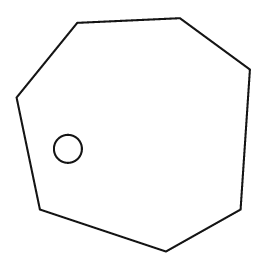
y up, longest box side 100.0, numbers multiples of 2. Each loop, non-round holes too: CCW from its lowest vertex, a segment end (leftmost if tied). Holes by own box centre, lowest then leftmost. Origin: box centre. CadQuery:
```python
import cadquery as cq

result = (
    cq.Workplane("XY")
    .moveTo(14.0, -50.0)
    .lineTo(46.0, -32.0)
    .lineTo(50.0, 28.0)
    .lineTo(20.0, 50.0)
    .lineTo(-24.0, 48.0)
    .lineTo(-50.0, 16.0)
    .lineTo(-40.0, -32.0)
    .close()
    .moveTo(-28.0, -6.0)
    .circle(6.0)
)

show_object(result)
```